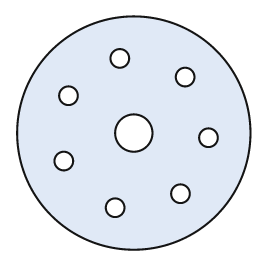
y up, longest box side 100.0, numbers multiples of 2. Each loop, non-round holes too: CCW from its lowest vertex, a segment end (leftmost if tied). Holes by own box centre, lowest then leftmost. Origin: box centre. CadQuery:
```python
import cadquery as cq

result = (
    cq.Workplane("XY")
    .moveTo(0.0, 0.0)
    .circle(50.0)
    .moveTo(-8.0, -32.0)
    .circle(4.0)
    .moveTo(20.0, -26.0)
    .circle(4.0)
    .moveTo(-30.0, -12.0)
    .circle(4.0)
    .moveTo(32.0, -2.0)
    .circle(4.0)
    .moveTo(0.0, 0.0)
    .circle(8.0)
    .moveTo(-28.0, 16.0)
    .circle(4.0)
    .moveTo(22.0, 24.0)
    .circle(4.0)
    .moveTo(-6.0, 32.0)
    .circle(4.0)
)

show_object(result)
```